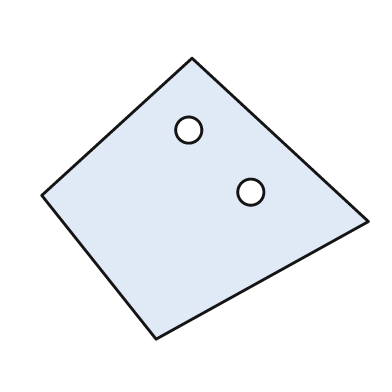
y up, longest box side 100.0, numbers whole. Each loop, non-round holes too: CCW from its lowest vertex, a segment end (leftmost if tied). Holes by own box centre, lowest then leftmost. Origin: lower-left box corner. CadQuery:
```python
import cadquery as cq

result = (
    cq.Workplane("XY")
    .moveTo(35.0, 0.0)
    .lineTo(100.0, 36.0)
    .lineTo(46.0, 86.0)
    .lineTo(0.0, 44.0)
    .close()
    .moveTo(64.0, 45.0)
    .circle(4.0)
    .moveTo(45.0, 64.0)
    .circle(4.0)
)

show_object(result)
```